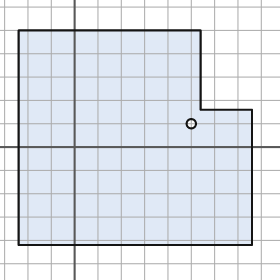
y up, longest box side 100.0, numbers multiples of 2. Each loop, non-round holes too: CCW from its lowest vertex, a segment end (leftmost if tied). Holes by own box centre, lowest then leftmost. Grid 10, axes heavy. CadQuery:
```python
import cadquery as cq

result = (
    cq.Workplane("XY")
    .moveTo(-24.0, -42.0)
    .lineTo(76.0, -42.0)
    .lineTo(76.0, 16.0)
    .lineTo(54.0, 16.0)
    .lineTo(54.0, 50.0)
    .lineTo(-24.0, 50.0)
    .close()
    .moveTo(50.0, 10.0)
    .circle(2.0)
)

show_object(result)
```